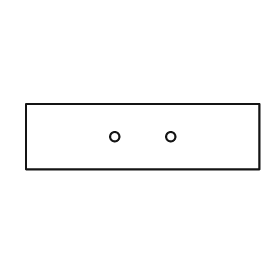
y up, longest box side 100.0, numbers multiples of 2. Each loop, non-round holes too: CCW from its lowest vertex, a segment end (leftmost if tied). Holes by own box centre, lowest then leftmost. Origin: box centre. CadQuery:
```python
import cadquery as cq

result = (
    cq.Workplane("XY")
    .moveTo(-50.0, -14.0)
    .lineTo(50.0, -14.0)
    .lineTo(50.0, 14.0)
    .lineTo(-50.0, 14.0)
    .close()
    .moveTo(-12.0, 0.0)
    .circle(2.0)
    .moveTo(12.0, 0.0)
    .circle(2.0)
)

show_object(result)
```